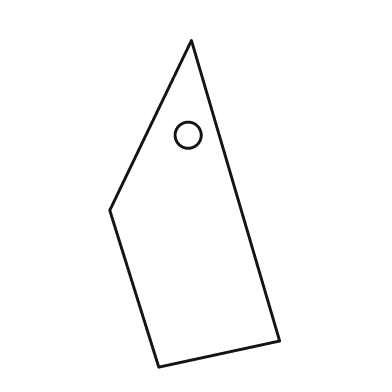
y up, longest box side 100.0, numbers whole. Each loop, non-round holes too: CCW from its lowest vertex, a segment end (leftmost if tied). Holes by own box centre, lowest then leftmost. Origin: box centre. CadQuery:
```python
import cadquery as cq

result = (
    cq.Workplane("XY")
    .moveTo(-11.0, -50.0)
    .lineTo(26.0, -42.0)
    .lineTo(-1.0, 50.0)
    .lineTo(-26.0, -2.0)
    .close()
    .moveTo(-2.0, 21.0)
    .circle(4.0)
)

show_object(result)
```